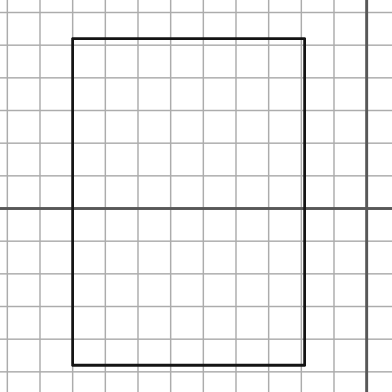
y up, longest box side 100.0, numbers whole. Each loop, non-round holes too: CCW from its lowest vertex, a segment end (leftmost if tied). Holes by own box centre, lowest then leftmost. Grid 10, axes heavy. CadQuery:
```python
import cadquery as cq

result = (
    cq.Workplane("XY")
    .moveTo(-90.0, -48.0)
    .lineTo(-19.0, -48.0)
    .lineTo(-19.0, 52.0)
    .lineTo(-90.0, 52.0)
    .close()
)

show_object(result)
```